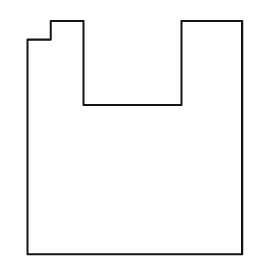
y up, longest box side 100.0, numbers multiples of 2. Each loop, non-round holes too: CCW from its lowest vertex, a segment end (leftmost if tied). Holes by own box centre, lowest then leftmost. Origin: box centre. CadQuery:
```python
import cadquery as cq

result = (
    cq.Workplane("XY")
    .moveTo(-46.0, -50.0)
    .lineTo(46.0, -50.0)
    .lineTo(46.0, 50.0)
    .lineTo(20.0, 50.0)
    .lineTo(20.0, 14.0)
    .lineTo(-22.0, 14.0)
    .lineTo(-22.0, 50.0)
    .lineTo(-36.0, 50.0)
    .lineTo(-36.0, 42.0)
    .lineTo(-46.0, 42.0)
    .close()
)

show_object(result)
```